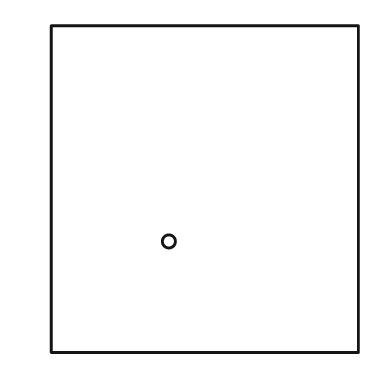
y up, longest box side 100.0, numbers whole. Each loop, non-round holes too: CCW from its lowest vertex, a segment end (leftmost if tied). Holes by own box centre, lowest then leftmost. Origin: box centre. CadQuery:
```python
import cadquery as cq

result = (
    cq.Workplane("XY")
    .moveTo(-47.0, -50.0)
    .lineTo(47.0, -50.0)
    .lineTo(47.0, 50.0)
    .lineTo(-47.0, 50.0)
    .close()
    .moveTo(-11.0, -16.0)
    .circle(2.0)
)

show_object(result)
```